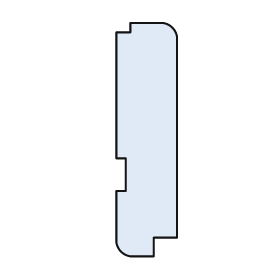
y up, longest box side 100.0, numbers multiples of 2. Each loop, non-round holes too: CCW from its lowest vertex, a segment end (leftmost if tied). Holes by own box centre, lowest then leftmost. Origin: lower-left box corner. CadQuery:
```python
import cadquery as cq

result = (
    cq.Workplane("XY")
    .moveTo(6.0, 0.0)
    .lineTo(16.0, 0.0)
    .lineTo(16.0, 8.0)
    .lineTo(26.0, 8.0)
    .lineTo(26.0, 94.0)
    .threePointArc((24.0, 98.0), (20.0, 100.0))
    .lineTo(6.0, 100.0)
    .lineTo(6.0, 96.0)
    .lineTo(0.0, 96.0)
    .lineTo(0.0, 42.0)
    .lineTo(4.0, 42.0)
    .lineTo(4.0, 28.0)
    .lineTo(0.0, 28.0)
    .lineTo(0.0, 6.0)
    .threePointArc((2.0, 2.0), (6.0, 0.0))
    .close()
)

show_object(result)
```